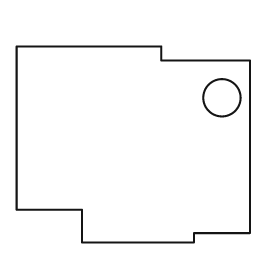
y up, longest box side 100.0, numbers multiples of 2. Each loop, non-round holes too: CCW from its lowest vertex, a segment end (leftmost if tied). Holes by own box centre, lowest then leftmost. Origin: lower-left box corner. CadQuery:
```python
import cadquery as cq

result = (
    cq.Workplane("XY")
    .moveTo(28.0, 0.0)
    .lineTo(76.0, 0.0)
    .lineTo(76.0, 4.0)
    .lineTo(100.0, 4.0)
    .lineTo(100.0, 78.0)
    .lineTo(62.0, 78.0)
    .lineTo(62.0, 84.0)
    .lineTo(0.0, 84.0)
    .lineTo(0.0, 14.0)
    .lineTo(28.0, 14.0)
    .close()
    .moveTo(88.0, 62.0)
    .circle(8.0)
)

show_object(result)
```